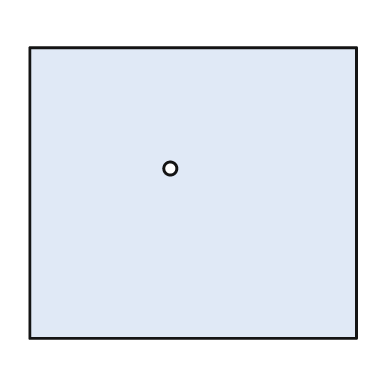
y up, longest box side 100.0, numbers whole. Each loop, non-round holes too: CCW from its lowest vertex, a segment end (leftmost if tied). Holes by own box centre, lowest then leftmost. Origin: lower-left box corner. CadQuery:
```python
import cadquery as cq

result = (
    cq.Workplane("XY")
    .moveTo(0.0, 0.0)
    .lineTo(100.0, 0.0)
    .lineTo(100.0, 89.0)
    .lineTo(0.0, 89.0)
    .close()
    .moveTo(43.0, 52.0)
    .circle(2.0)
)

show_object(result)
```